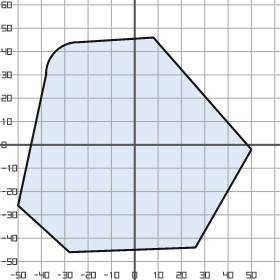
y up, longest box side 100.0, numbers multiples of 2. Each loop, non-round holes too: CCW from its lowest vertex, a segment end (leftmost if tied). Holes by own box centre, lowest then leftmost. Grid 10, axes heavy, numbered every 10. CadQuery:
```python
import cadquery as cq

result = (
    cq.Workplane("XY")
    .moveTo(-28.0, -46.0)
    .lineTo(26.0, -44.0)
    .lineTo(50.0, -2.0)
    .lineTo(8.0, 46.0)
    .lineTo(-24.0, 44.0)
    .threePointArc((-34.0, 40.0), (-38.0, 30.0))
    .lineTo(-50.0, -26.0)
    .close()
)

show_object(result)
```